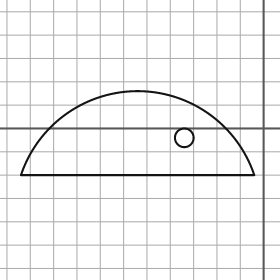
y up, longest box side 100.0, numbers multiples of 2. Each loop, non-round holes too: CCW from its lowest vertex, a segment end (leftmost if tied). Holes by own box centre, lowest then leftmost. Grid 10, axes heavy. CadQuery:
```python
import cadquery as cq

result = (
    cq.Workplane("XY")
    .moveTo(-104.0, -20.0)
    .lineTo(-4.0, -20.0)
    .threePointArc((-54.0, 16.0), (-104.0, -20.0))
    .close()
    .moveTo(-34.0, -4.0)
    .circle(4.0)
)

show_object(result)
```